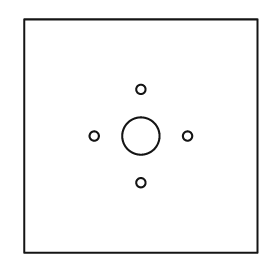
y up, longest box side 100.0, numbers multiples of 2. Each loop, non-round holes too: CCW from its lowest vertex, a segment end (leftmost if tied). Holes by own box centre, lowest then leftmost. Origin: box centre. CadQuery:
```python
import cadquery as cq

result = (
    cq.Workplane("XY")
    .moveTo(-50.0, -50.0)
    .lineTo(50.0, -50.0)
    .lineTo(50.0, 50.0)
    .lineTo(-50.0, 50.0)
    .close()
    .moveTo(0.0, -20.0)
    .circle(2.0)
    .moveTo(-20.0, 0.0)
    .circle(2.0)
    .moveTo(0.0, 0.0)
    .circle(8.0)
    .moveTo(20.0, 0.0)
    .circle(2.0)
    .moveTo(0.0, 20.0)
    .circle(2.0)
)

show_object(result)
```